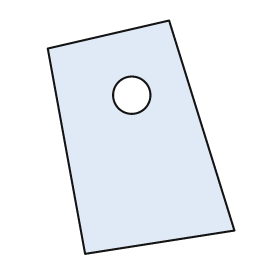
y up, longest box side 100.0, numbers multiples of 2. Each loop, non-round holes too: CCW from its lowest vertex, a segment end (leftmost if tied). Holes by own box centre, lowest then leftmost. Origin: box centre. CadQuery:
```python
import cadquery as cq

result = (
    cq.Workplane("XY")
    .moveTo(-24.0, -50.0)
    .lineTo(40.0, -40.0)
    .lineTo(12.0, 50.0)
    .lineTo(-40.0, 38.0)
    .close()
    .moveTo(-4.0, 18.0)
    .circle(8.0)
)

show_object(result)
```